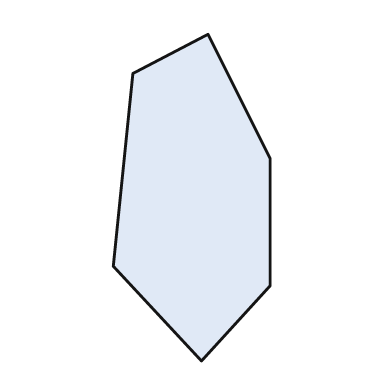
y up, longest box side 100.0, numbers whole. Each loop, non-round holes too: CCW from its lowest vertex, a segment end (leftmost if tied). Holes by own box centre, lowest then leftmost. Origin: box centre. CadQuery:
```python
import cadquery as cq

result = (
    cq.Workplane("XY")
    .moveTo(3.0, -50.0)
    .lineTo(24.0, -27.0)
    .lineTo(24.0, 12.0)
    .lineTo(5.0, 50.0)
    .lineTo(-18.0, 38.0)
    .lineTo(-24.0, -21.0)
    .close()
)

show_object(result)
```